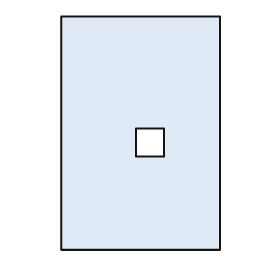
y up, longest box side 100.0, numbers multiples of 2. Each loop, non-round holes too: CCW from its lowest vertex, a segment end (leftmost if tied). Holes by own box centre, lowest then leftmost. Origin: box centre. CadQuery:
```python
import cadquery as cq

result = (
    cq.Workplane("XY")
    .moveTo(-34.0, -50.0)
    .lineTo(34.0, -50.0)
    .lineTo(34.0, 50.0)
    .lineTo(-34.0, 50.0)
    .close()
    .moveTo(-2.0, -10.0)
    .lineTo(10.0, -10.0)
    .lineTo(10.0, 2.0)
    .lineTo(-2.0, 2.0)
    .close()
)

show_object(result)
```